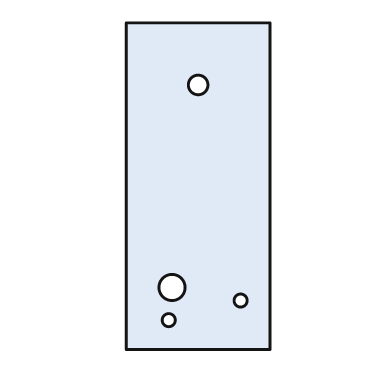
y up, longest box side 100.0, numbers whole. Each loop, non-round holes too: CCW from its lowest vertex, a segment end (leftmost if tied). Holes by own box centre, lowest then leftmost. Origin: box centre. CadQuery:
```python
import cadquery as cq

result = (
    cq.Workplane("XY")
    .moveTo(-22.0, -50.0)
    .lineTo(22.0, -50.0)
    .lineTo(22.0, 50.0)
    .lineTo(-22.0, 50.0)
    .close()
    .moveTo(-9.0, -41.0)
    .circle(2.0)
    .moveTo(13.0, -35.0)
    .circle(2.0)
    .moveTo(-8.0, -31.0)
    .circle(4.0)
    .moveTo(0.0, 31.0)
    .circle(3.0)
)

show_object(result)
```